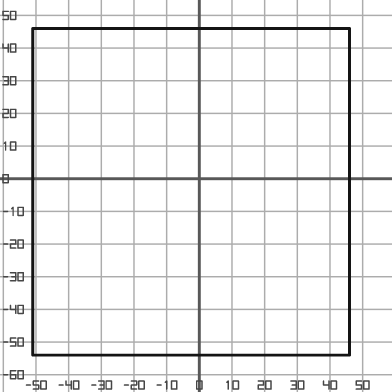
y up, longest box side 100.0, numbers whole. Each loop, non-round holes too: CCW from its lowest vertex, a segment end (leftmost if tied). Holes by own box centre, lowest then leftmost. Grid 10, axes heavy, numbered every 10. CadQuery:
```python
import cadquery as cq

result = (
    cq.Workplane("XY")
    .moveTo(-51.0, -54.0)
    .lineTo(46.0, -54.0)
    .lineTo(46.0, 46.0)
    .lineTo(-51.0, 46.0)
    .close()
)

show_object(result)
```